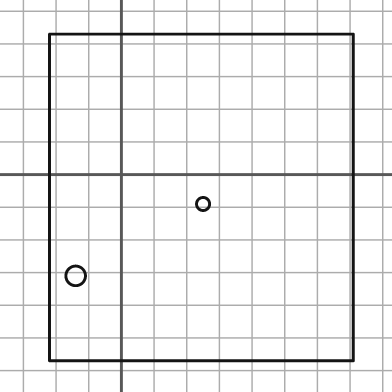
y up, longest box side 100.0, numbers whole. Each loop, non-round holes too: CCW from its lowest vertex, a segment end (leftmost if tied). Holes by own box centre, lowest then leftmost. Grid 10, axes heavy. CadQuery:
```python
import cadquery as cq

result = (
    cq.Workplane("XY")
    .moveTo(-22.0, -57.0)
    .lineTo(71.0, -57.0)
    .lineTo(71.0, 43.0)
    .lineTo(-22.0, 43.0)
    .close()
    .moveTo(-14.0, -31.0)
    .circle(3.0)
    .moveTo(25.0, -9.0)
    .circle(2.0)
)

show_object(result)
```